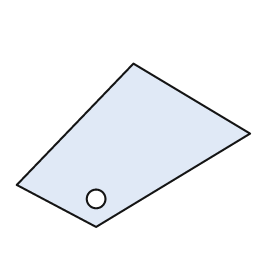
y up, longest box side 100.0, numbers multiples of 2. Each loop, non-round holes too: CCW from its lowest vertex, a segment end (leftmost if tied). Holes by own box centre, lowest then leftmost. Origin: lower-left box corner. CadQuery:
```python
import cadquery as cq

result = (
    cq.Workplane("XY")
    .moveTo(34.0, 0.0)
    .lineTo(100.0, 40.0)
    .lineTo(50.0, 70.0)
    .lineTo(0.0, 18.0)
    .close()
    .moveTo(34.0, 12.0)
    .circle(4.0)
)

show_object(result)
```